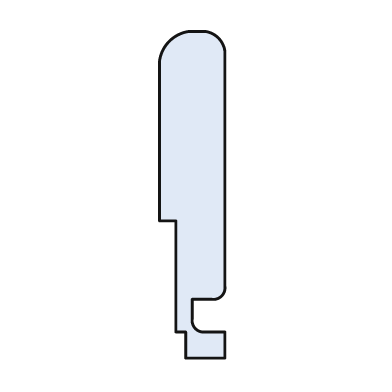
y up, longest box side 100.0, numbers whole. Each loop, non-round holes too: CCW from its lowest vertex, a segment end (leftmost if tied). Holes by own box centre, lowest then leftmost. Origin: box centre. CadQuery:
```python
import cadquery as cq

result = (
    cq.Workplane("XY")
    .moveTo(-2.0, -50.0)
    .lineTo(10.0, -50.0)
    .lineTo(10.0, -42.0)
    .lineTo(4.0, -42.0)
    .threePointArc((1.0, -41.0), (0.0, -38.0))
    .lineTo(0.0, -32.0)
    .lineTo(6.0, -32.0)
    .threePointArc((9.0, -31.0), (10.0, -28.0))
    .lineTo(10.0, 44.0)
    .threePointArc((8.0, 48.0), (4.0, 50.0))
    .lineTo(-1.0, 50.0)
    .threePointArc((-7.0, 47.0), (-10.0, 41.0))
    .lineTo(-10.0, -8.0)
    .lineTo(-5.0, -8.0)
    .lineTo(-5.0, -42.0)
    .lineTo(-2.0, -42.0)
    .close()
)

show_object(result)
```